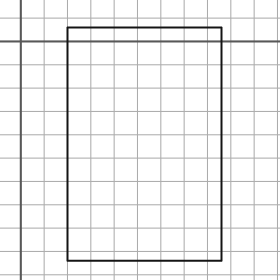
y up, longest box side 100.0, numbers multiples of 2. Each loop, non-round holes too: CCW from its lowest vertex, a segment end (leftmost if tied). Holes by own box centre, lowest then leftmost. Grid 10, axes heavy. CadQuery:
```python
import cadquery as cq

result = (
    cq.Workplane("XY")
    .moveTo(20.0, -94.0)
    .lineTo(86.0, -94.0)
    .lineTo(86.0, 6.0)
    .lineTo(20.0, 6.0)
    .close()
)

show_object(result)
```